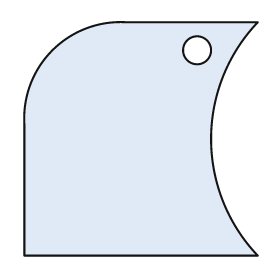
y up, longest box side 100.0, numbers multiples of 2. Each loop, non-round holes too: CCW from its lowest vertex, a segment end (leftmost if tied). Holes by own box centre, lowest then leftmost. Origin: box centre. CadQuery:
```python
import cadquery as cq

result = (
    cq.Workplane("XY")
    .moveTo(-50.0, -50.0)
    .lineTo(50.0, -50.0)
    .threePointArc((30.0, 0.0), (50.0, 50.0))
    .lineTo(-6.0, 50.0)
    .threePointArc((-38.0, 38.0), (-50.0, 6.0))
    .close()
    .moveTo(24.0, 38.0)
    .circle(6.0)
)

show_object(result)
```